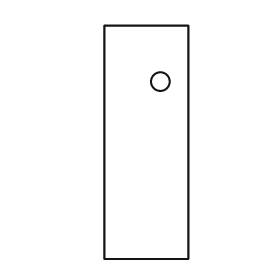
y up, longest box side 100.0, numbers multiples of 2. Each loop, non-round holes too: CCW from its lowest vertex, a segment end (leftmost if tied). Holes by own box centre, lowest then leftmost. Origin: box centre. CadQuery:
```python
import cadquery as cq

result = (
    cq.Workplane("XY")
    .moveTo(-18.0, -50.0)
    .lineTo(18.0, -50.0)
    .lineTo(18.0, 50.0)
    .lineTo(-18.0, 50.0)
    .close()
    .moveTo(6.0, 26.0)
    .circle(4.0)
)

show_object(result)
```